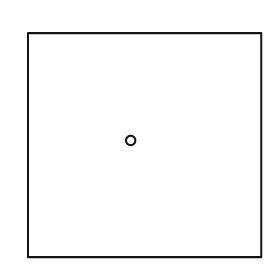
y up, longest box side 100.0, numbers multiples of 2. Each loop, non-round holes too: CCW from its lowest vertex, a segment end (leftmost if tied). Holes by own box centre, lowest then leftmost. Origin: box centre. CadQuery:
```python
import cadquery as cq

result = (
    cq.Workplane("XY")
    .moveTo(-50.0, -48.0)
    .lineTo(50.0, -48.0)
    .lineTo(50.0, 48.0)
    .lineTo(-50.0, 48.0)
    .close()
    .moveTo(-6.0, 2.0)
    .circle(2.0)
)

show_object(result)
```